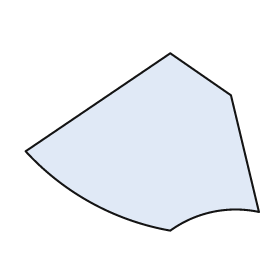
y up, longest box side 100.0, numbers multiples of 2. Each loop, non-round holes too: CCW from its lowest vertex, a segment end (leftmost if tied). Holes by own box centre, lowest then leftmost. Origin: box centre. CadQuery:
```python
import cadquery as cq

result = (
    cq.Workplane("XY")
    .moveTo(12.0, -38.0)
    .threePointArc((30.0, -30.0), (50.0, -30.0))
    .lineTo(38.0, 20.0)
    .lineTo(12.0, 38.0)
    .lineTo(-50.0, -4.0)
    .threePointArc((-22.0, -26.0), (12.0, -38.0))
    .close()
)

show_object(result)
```